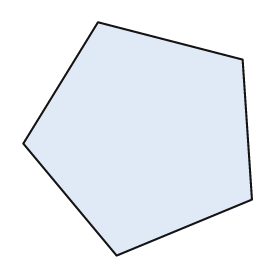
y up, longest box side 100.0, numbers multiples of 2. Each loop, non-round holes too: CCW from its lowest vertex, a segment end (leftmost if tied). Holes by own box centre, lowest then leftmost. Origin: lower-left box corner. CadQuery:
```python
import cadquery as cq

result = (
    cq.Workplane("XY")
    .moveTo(40.0, 0.0)
    .lineTo(98.0, 24.0)
    .lineTo(94.0, 84.0)
    .lineTo(32.0, 100.0)
    .lineTo(0.0, 48.0)
    .close()
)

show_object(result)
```